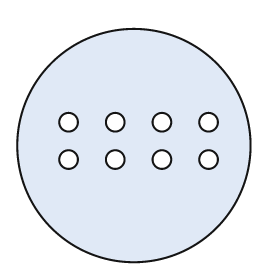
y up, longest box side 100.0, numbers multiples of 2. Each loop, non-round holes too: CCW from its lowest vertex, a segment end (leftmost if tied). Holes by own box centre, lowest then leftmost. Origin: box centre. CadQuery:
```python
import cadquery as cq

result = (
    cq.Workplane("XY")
    .moveTo(0.0, 0.0)
    .circle(50.0)
    .moveTo(-28.0, -6.0)
    .circle(4.0)
    .moveTo(-8.0, -6.0)
    .circle(4.0)
    .moveTo(12.0, -6.0)
    .circle(4.0)
    .moveTo(32.0, -6.0)
    .circle(4.0)
    .moveTo(-28.0, 10.0)
    .circle(4.0)
    .moveTo(-8.0, 10.0)
    .circle(4.0)
    .moveTo(12.0, 10.0)
    .circle(4.0)
    .moveTo(32.0, 10.0)
    .circle(4.0)
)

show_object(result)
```